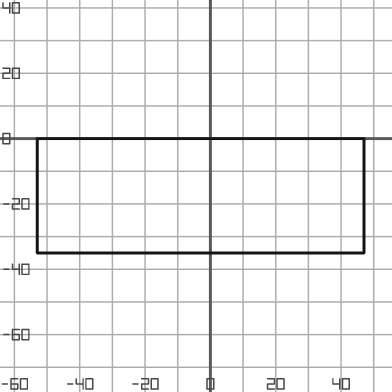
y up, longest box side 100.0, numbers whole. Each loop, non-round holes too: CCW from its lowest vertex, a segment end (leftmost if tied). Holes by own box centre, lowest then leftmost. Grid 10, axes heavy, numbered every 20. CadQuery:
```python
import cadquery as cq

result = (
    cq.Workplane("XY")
    .moveTo(-53.0, -35.0)
    .lineTo(47.0, -35.0)
    .lineTo(47.0, 0.0)
    .lineTo(-53.0, 0.0)
    .close()
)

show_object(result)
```